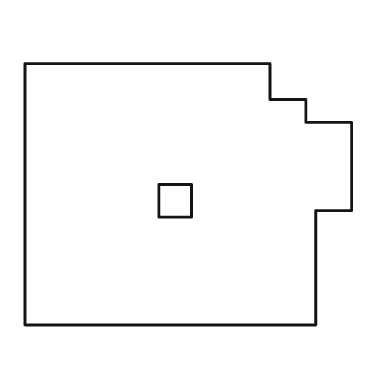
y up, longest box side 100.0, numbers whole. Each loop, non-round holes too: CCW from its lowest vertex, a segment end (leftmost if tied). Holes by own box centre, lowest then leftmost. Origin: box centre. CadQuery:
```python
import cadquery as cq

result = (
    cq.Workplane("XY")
    .moveTo(-50.0, -40.0)
    .lineTo(39.0, -40.0)
    .lineTo(39.0, -5.0)
    .lineTo(50.0, -5.0)
    .lineTo(50.0, 22.0)
    .lineTo(36.0, 22.0)
    .lineTo(36.0, 29.0)
    .lineTo(25.0, 29.0)
    .lineTo(25.0, 40.0)
    .lineTo(-50.0, 40.0)
    .close()
    .moveTo(-9.0, -7.0)
    .lineTo(1.0, -7.0)
    .lineTo(1.0, 3.0)
    .lineTo(-9.0, 3.0)
    .close()
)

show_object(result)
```